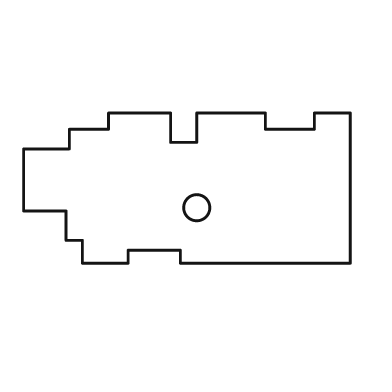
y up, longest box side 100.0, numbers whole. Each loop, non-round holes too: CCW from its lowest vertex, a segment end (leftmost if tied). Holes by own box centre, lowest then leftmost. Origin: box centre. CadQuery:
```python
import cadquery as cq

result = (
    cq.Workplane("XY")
    .moveTo(-32.0, -23.0)
    .lineTo(-18.0, -23.0)
    .lineTo(-18.0, -19.0)
    .lineTo(-2.0, -19.0)
    .lineTo(-2.0, -23.0)
    .lineTo(50.0, -23.0)
    .lineTo(50.0, 23.0)
    .lineTo(39.0, 23.0)
    .lineTo(39.0, 18.0)
    .lineTo(24.0, 18.0)
    .lineTo(24.0, 23.0)
    .lineTo(3.0, 23.0)
    .lineTo(3.0, 14.0)
    .lineTo(-5.0, 14.0)
    .lineTo(-5.0, 23.0)
    .lineTo(-24.0, 23.0)
    .lineTo(-24.0, 18.0)
    .lineTo(-36.0, 18.0)
    .lineTo(-36.0, 12.0)
    .lineTo(-50.0, 12.0)
    .lineTo(-50.0, -7.0)
    .lineTo(-37.0, -7.0)
    .lineTo(-37.0, -16.0)
    .lineTo(-32.0, -16.0)
    .close()
    .moveTo(3.0, -6.0)
    .circle(4.0)
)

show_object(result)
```